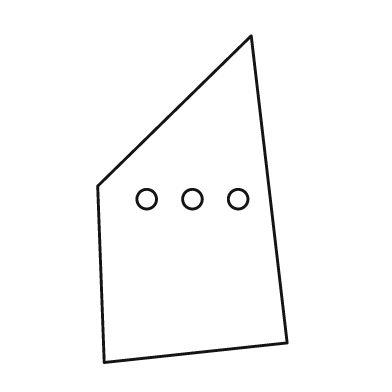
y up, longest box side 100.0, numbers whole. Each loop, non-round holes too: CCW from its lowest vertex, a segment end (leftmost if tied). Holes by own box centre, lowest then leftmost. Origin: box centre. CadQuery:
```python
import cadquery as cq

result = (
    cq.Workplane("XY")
    .moveTo(-27.0, -50.0)
    .lineTo(29.0, -44.0)
    .lineTo(18.0, 50.0)
    .lineTo(-29.0, 4.0)
    .close()
    .moveTo(-14.0, 0.0)
    .circle(3.0)
    .moveTo(0.0, 0.0)
    .circle(3.0)
    .moveTo(14.0, 0.0)
    .circle(3.0)
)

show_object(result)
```